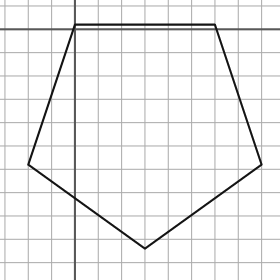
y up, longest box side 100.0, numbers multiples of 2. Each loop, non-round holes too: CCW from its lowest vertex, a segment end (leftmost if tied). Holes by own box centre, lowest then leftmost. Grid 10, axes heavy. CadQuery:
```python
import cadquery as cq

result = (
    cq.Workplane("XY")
    .moveTo(30.0, -94.0)
    .lineTo(80.0, -58.0)
    .lineTo(60.0, 2.0)
    .lineTo(0.0, 2.0)
    .lineTo(-20.0, -58.0)
    .close()
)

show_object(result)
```